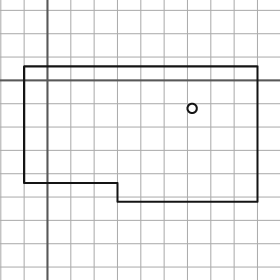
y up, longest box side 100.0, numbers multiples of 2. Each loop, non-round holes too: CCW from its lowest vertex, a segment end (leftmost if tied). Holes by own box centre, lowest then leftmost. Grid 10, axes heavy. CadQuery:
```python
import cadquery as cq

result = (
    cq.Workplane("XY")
    .moveTo(30.0, -52.0)
    .lineTo(90.0, -52.0)
    .lineTo(90.0, 6.0)
    .lineTo(-10.0, 6.0)
    .lineTo(-10.0, -44.0)
    .lineTo(30.0, -44.0)
    .close()
    .moveTo(62.0, -12.0)
    .circle(2.0)
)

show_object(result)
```